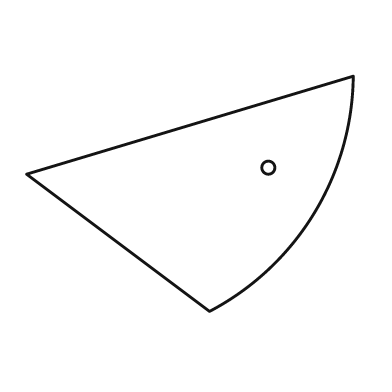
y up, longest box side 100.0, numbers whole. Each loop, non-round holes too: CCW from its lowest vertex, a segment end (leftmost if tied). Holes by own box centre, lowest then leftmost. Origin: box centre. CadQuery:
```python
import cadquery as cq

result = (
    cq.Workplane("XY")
    .moveTo(6.0, -36.0)
    .threePointArc((38.0, -6.0), (50.0, 36.0))
    .lineTo(-50.0, 6.0)
    .close()
    .moveTo(24.0, 8.0)
    .circle(2.0)
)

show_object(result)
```